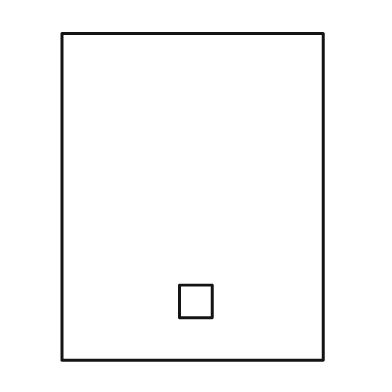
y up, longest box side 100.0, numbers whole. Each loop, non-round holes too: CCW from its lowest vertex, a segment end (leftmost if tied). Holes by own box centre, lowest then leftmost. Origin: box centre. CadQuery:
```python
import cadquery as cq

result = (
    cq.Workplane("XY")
    .moveTo(-40.0, -50.0)
    .lineTo(40.0, -50.0)
    .lineTo(40.0, 50.0)
    .lineTo(-40.0, 50.0)
    .close()
    .moveTo(-4.0, -37.0)
    .lineTo(6.0, -37.0)
    .lineTo(6.0, -27.0)
    .lineTo(-4.0, -27.0)
    .close()
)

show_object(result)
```